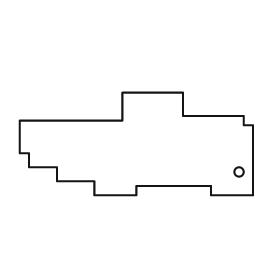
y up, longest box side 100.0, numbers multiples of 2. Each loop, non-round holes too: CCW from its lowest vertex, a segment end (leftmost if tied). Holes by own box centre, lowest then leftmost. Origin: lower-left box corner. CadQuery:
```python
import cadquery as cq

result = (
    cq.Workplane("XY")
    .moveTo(32.0, 0.0)
    .lineTo(50.0, 0.0)
    .lineTo(50.0, 4.0)
    .lineTo(82.0, 4.0)
    .lineTo(82.0, 0.0)
    .lineTo(100.0, 0.0)
    .lineTo(100.0, 30.0)
    .lineTo(96.0, 30.0)
    .lineTo(96.0, 34.0)
    .lineTo(70.0, 34.0)
    .lineTo(70.0, 44.0)
    .lineTo(44.0, 44.0)
    .lineTo(44.0, 32.0)
    .lineTo(0.0, 32.0)
    .lineTo(0.0, 18.0)
    .lineTo(4.0, 18.0)
    .lineTo(4.0, 12.0)
    .lineTo(16.0, 12.0)
    .lineTo(16.0, 6.0)
    .lineTo(32.0, 6.0)
    .close()
    .moveTo(94.0, 10.0)
    .circle(2.0)
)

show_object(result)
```